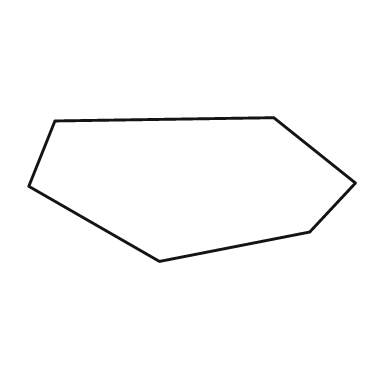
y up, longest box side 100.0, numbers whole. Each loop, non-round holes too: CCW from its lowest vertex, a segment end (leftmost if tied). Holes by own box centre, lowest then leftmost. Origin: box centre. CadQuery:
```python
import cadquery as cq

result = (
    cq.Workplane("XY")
    .moveTo(-10.0, -22.0)
    .lineTo(36.0, -13.0)
    .lineTo(50.0, 2.0)
    .lineTo(25.0, 22.0)
    .lineTo(-42.0, 21.0)
    .lineTo(-50.0, 1.0)
    .close()
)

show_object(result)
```